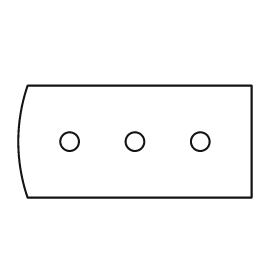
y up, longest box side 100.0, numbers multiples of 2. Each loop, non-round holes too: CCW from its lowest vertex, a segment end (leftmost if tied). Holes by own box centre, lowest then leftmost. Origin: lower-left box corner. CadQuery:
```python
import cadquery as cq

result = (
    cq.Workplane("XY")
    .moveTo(4.0, 0.0)
    .lineTo(100.0, 0.0)
    .lineTo(100.0, 48.0)
    .lineTo(4.0, 48.0)
    .threePointArc((0.0, 24.0), (4.0, 0.0))
    .close()
    .moveTo(22.0, 24.0)
    .circle(4.0)
    .moveTo(50.0, 24.0)
    .circle(4.0)
    .moveTo(78.0, 24.0)
    .circle(4.0)
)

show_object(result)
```